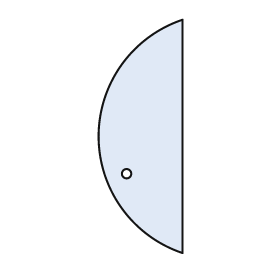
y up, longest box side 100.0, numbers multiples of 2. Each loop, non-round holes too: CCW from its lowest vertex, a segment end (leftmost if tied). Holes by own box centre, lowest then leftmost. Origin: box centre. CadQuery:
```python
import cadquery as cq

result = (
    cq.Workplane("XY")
    .moveTo(18.0, -50.0)
    .lineTo(18.0, 50.0)
    .threePointArc((-18.0, 0.0), (18.0, -50.0))
    .close()
    .moveTo(-6.0, -16.0)
    .circle(2.0)
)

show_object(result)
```